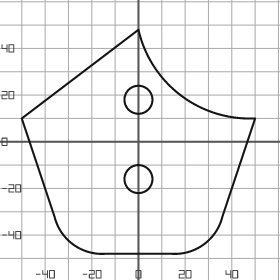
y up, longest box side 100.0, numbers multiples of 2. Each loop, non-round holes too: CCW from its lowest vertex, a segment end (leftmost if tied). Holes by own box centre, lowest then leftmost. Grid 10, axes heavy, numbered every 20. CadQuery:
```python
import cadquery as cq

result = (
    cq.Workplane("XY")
    .moveTo(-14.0, -48.0)
    .lineTo(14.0, -48.0)
    .threePointArc((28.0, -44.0), (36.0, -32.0))
    .lineTo(50.0, 10.0)
    .threePointArc((18.0, 20.0), (0.0, 48.0))
    .lineTo(-50.0, 10.0)
    .lineTo(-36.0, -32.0)
    .threePointArc((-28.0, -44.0), (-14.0, -48.0))
    .close()
    .moveTo(0.0, -16.0)
    .circle(6.0)
    .moveTo(0.0, 18.0)
    .circle(6.0)
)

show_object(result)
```